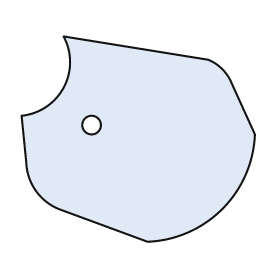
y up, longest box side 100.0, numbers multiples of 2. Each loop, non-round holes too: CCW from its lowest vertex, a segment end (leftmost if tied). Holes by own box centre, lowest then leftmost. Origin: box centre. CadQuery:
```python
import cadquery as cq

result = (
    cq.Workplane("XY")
    .moveTo(4.0, -44.0)
    .threePointArc((36.0, -30.0), (50.0, 2.0))
    .lineTo(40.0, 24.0)
    .threePointArc((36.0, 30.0), (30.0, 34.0))
    .lineTo(-32.0, 44.0)
    .threePointArc((-32.0, 22.0), (-50.0, 10.0))
    .lineTo(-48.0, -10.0)
    .threePointArc((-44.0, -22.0), (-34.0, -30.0))
    .close()
    .moveTo(-20.0, 6.0)
    .circle(4.0)
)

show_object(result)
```